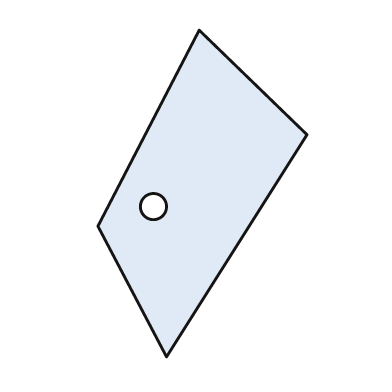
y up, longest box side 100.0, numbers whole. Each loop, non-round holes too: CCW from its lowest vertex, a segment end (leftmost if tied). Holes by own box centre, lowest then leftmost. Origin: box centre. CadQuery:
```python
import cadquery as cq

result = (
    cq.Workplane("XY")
    .moveTo(-11.0, -50.0)
    .lineTo(32.0, 18.0)
    .lineTo(-1.0, 50.0)
    .lineTo(-32.0, -10.0)
    .close()
    .moveTo(-15.0, -4.0)
    .circle(4.0)
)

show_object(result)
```